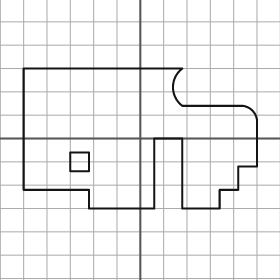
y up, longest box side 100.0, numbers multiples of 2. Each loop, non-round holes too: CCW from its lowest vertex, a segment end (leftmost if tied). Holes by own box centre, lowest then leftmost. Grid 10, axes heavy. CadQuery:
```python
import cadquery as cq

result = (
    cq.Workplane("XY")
    .moveTo(-22.0, -30.0)
    .lineTo(6.0, -30.0)
    .lineTo(6.0, 0.0)
    .lineTo(18.0, 0.0)
    .lineTo(18.0, -30.0)
    .lineTo(34.0, -30.0)
    .lineTo(34.0, -22.0)
    .lineTo(42.0, -22.0)
    .lineTo(42.0, -12.0)
    .lineTo(50.0, -12.0)
    .lineTo(50.0, 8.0)
    .threePointArc((48.0, 12.0), (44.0, 14.0))
    .lineTo(18.0, 14.0)
    .threePointArc((14.0, 22.0), (18.0, 30.0))
    .lineTo(-50.0, 30.0)
    .lineTo(-50.0, -22.0)
    .lineTo(-22.0, -22.0)
    .close()
    .moveTo(-30.0, -14.0)
    .lineTo(-22.0, -14.0)
    .lineTo(-22.0, -6.0)
    .lineTo(-30.0, -6.0)
    .close()
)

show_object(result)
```